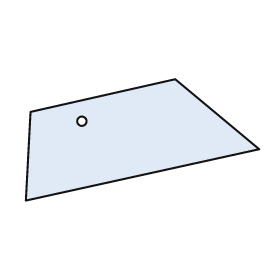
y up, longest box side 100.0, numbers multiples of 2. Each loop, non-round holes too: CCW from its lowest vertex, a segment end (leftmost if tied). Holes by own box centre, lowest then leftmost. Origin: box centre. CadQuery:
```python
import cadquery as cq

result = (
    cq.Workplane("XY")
    .moveTo(-50.0, -26.0)
    .lineTo(50.0, -4.0)
    .lineTo(14.0, 26.0)
    .lineTo(-48.0, 12.0)
    .close()
    .moveTo(-26.0, 8.0)
    .circle(2.0)
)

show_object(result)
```